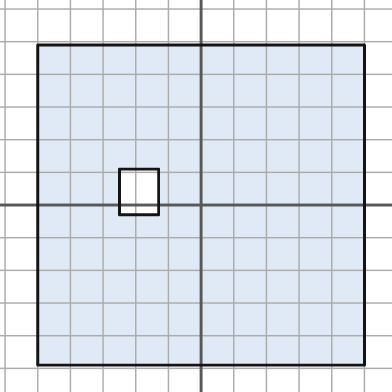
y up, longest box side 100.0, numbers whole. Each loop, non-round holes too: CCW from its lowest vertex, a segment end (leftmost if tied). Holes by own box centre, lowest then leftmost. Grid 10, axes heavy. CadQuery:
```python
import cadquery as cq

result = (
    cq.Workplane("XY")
    .moveTo(-50.0, -49.0)
    .lineTo(50.0, -49.0)
    .lineTo(50.0, 49.0)
    .lineTo(-50.0, 49.0)
    .close()
    .moveTo(-25.0, -3.0)
    .lineTo(-13.0, -3.0)
    .lineTo(-13.0, 11.0)
    .lineTo(-25.0, 11.0)
    .close()
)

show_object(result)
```